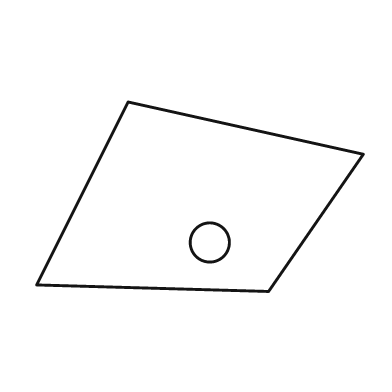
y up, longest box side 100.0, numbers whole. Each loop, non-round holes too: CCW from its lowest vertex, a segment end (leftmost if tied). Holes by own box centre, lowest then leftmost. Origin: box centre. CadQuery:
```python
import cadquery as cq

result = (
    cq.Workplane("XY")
    .moveTo(21.0, -29.0)
    .lineTo(50.0, 13.0)
    .lineTo(-22.0, 29.0)
    .lineTo(-50.0, -27.0)
    .close()
    .moveTo(3.0, -14.0)
    .circle(6.0)
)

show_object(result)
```